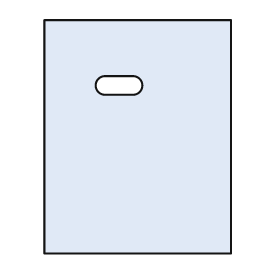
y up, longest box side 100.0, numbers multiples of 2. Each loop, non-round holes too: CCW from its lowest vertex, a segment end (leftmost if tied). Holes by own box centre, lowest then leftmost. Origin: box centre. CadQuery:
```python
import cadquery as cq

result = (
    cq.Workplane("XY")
    .moveTo(-40.0, -50.0)
    .lineTo(40.0, -50.0)
    .lineTo(40.0, 50.0)
    .lineTo(-40.0, 50.0)
    .close()
    .moveTo(-14.0, 18.0)
    .lineTo(-2.0, 18.0)
    .threePointArc((2.0, 22.0), (-2.0, 26.0))
    .lineTo(-14.0, 26.0)
    .threePointArc((-18.0, 22.0), (-14.0, 18.0))
    .close()
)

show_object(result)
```